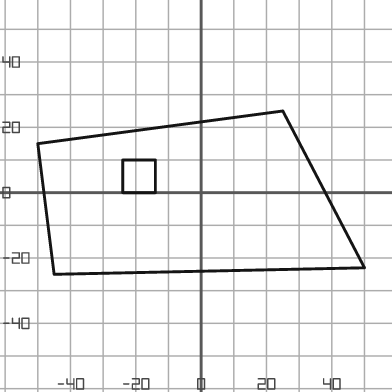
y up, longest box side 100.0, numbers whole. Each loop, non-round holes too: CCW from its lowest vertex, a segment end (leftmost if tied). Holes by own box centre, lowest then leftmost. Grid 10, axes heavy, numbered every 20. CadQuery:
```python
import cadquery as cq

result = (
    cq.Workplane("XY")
    .moveTo(-45.0, -25.0)
    .lineTo(50.0, -23.0)
    .lineTo(25.0, 25.0)
    .lineTo(-50.0, 15.0)
    .close()
    .moveTo(-24.0, 0.0)
    .lineTo(-14.0, 0.0)
    .lineTo(-14.0, 10.0)
    .lineTo(-24.0, 10.0)
    .close()
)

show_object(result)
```